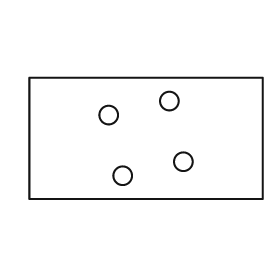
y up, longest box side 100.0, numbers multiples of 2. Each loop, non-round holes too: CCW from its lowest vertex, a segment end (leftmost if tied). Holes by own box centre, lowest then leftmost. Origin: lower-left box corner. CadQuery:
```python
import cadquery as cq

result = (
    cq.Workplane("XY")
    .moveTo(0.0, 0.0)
    .lineTo(100.0, 0.0)
    .lineTo(100.0, 52.0)
    .lineTo(0.0, 52.0)
    .close()
    .moveTo(40.0, 10.0)
    .circle(4.0)
    .moveTo(66.0, 16.0)
    .circle(4.0)
    .moveTo(34.0, 36.0)
    .circle(4.0)
    .moveTo(60.0, 42.0)
    .circle(4.0)
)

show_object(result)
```